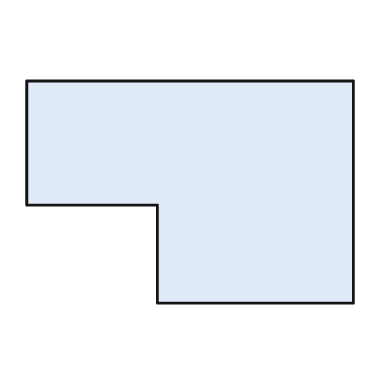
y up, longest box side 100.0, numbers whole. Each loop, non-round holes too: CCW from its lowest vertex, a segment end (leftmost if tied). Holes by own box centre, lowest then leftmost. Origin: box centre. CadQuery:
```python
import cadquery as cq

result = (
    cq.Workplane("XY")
    .moveTo(-10.0, -34.0)
    .lineTo(50.0, -34.0)
    .lineTo(50.0, 34.0)
    .lineTo(-50.0, 34.0)
    .lineTo(-50.0, -4.0)
    .lineTo(-10.0, -4.0)
    .close()
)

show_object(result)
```